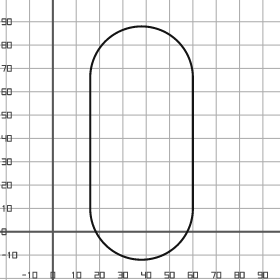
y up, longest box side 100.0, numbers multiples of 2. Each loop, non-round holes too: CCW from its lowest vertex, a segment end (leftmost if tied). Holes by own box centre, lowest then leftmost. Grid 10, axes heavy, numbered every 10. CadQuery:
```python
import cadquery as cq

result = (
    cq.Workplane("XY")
    .moveTo(16.0, 10.0)
    .threePointArc((38.0, -12.0), (60.0, 10.0))
    .lineTo(60.0, 66.0)
    .threePointArc((38.0, 88.0), (16.0, 66.0))
    .close()
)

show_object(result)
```